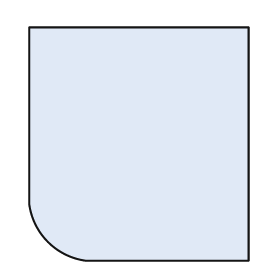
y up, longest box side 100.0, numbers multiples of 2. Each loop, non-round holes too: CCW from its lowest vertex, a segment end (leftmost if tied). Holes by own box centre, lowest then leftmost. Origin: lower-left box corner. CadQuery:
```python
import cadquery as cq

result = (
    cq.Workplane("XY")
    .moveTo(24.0, 0.0)
    .lineTo(94.0, 0.0)
    .lineTo(94.0, 100.0)
    .lineTo(0.0, 100.0)
    .lineTo(0.0, 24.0)
    .threePointArc((8.0, 8.0), (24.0, 0.0))
    .close()
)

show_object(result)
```